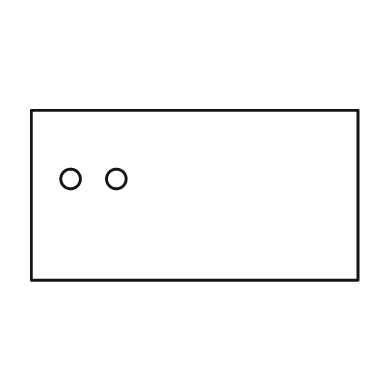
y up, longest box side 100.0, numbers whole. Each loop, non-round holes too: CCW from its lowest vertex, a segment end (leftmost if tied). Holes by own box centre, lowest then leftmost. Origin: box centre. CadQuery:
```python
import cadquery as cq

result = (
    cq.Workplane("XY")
    .moveTo(-50.0, -26.0)
    .lineTo(50.0, -26.0)
    .lineTo(50.0, 26.0)
    .lineTo(-50.0, 26.0)
    .close()
    .moveTo(-38.0, 5.0)
    .circle(3.0)
    .moveTo(-24.0, 5.0)
    .circle(3.0)
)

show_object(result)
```